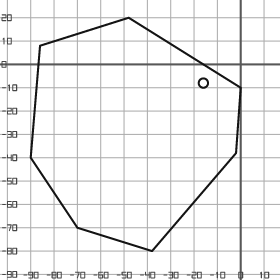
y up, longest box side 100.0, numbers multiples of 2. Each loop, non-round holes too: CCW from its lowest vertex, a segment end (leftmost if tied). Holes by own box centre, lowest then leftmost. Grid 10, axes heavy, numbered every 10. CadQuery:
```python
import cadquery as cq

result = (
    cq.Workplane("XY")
    .moveTo(-38.0, -80.0)
    .lineTo(-2.0, -38.0)
    .lineTo(0.0, -10.0)
    .lineTo(-48.0, 20.0)
    .lineTo(-86.0, 8.0)
    .lineTo(-90.0, -40.0)
    .lineTo(-70.0, -70.0)
    .close()
    .moveTo(-16.0, -8.0)
    .circle(2.0)
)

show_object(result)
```